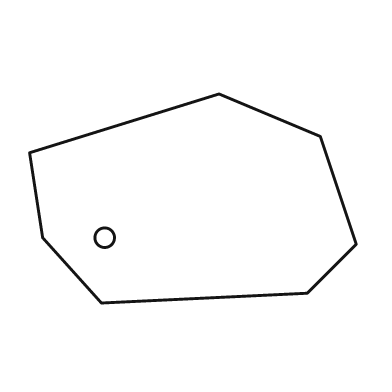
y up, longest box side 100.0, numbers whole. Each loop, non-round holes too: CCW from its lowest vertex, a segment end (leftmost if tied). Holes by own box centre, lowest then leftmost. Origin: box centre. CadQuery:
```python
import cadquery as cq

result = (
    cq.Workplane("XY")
    .moveTo(-28.0, -32.0)
    .lineTo(35.0, -29.0)
    .lineTo(50.0, -14.0)
    .lineTo(39.0, 19.0)
    .lineTo(8.0, 32.0)
    .lineTo(-50.0, 14.0)
    .lineTo(-46.0, -12.0)
    .close()
    .moveTo(-27.0, -12.0)
    .circle(3.0)
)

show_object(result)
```